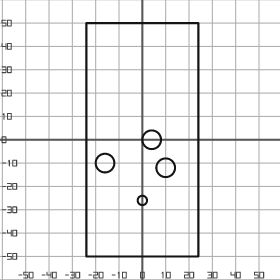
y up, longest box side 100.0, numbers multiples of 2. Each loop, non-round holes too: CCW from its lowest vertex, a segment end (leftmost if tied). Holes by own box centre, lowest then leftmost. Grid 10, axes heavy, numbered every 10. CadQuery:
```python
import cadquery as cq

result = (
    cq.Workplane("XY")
    .moveTo(-24.0, -50.0)
    .lineTo(24.0, -50.0)
    .lineTo(24.0, 50.0)
    .lineTo(-24.0, 50.0)
    .close()
    .moveTo(0.0, -26.0)
    .circle(2.0)
    .moveTo(10.0, -12.0)
    .circle(4.0)
    .moveTo(-16.0, -10.0)
    .circle(4.0)
    .moveTo(4.0, 0.0)
    .circle(4.0)
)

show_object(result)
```